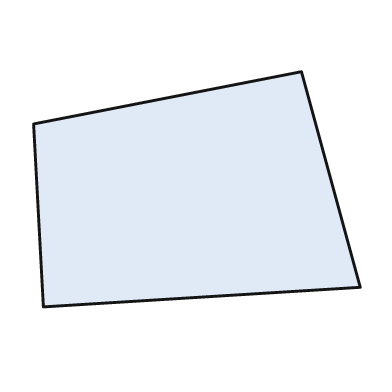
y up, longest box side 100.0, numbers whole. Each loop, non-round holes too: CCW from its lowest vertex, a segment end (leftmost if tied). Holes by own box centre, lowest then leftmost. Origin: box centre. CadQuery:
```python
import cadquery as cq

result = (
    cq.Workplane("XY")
    .moveTo(-47.0, -36.0)
    .lineTo(50.0, -30.0)
    .lineTo(32.0, 36.0)
    .lineTo(-50.0, 20.0)
    .close()
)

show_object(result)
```